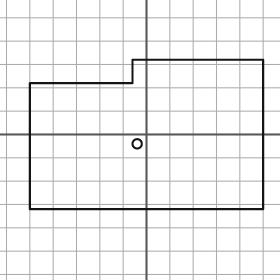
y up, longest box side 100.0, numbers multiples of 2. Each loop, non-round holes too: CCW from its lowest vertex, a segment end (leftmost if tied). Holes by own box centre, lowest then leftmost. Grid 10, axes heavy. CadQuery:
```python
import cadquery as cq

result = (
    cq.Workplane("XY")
    .moveTo(-50.0, -32.0)
    .lineTo(50.0, -32.0)
    .lineTo(50.0, 32.0)
    .lineTo(-6.0, 32.0)
    .lineTo(-6.0, 22.0)
    .lineTo(-50.0, 22.0)
    .close()
    .moveTo(-4.0, -4.0)
    .circle(2.0)
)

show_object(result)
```